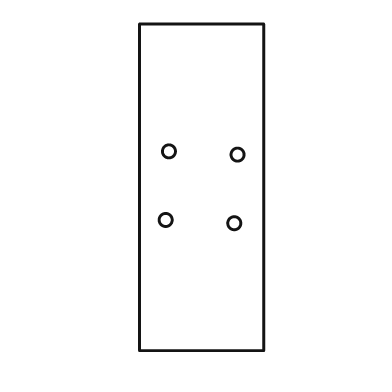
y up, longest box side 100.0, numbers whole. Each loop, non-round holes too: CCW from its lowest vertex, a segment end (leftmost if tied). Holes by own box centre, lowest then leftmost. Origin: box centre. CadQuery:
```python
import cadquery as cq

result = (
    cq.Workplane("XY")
    .moveTo(-19.0, -50.0)
    .lineTo(19.0, -50.0)
    .lineTo(19.0, 50.0)
    .lineTo(-19.0, 50.0)
    .close()
    .moveTo(10.0, -11.0)
    .circle(2.0)
    .moveTo(-11.0, -10.0)
    .circle(2.0)
    .moveTo(11.0, 10.0)
    .circle(2.0)
    .moveTo(-10.0, 11.0)
    .circle(2.0)
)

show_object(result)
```